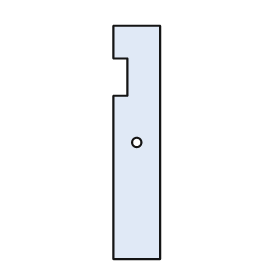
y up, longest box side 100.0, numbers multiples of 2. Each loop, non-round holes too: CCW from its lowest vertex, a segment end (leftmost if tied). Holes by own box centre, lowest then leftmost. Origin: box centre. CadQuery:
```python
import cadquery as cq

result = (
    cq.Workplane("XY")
    .moveTo(-10.0, -50.0)
    .lineTo(10.0, -50.0)
    .lineTo(10.0, 50.0)
    .lineTo(-10.0, 50.0)
    .lineTo(-10.0, 36.0)
    .lineTo(-4.0, 36.0)
    .lineTo(-4.0, 20.0)
    .lineTo(-10.0, 20.0)
    .close()
    .moveTo(0.0, 0.0)
    .circle(2.0)
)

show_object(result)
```